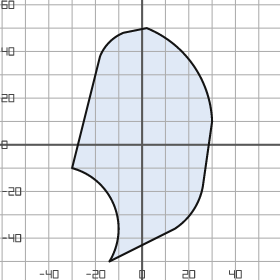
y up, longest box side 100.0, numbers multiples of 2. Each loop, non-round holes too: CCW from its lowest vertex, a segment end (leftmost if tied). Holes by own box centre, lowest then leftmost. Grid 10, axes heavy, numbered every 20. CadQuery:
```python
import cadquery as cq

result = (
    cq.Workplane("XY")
    .moveTo(-14.0, -50.0)
    .lineTo(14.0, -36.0)
    .threePointArc((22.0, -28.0), (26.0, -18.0))
    .lineTo(30.0, 10.0)
    .threePointArc((22.0, 34.0), (2.0, 50.0))
    .lineTo(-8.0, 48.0)
    .threePointArc((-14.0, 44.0), (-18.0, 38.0))
    .lineTo(-30.0, -10.0)
    .threePointArc((-12.0, -26.0), (-14.0, -50.0))
    .close()
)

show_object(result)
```